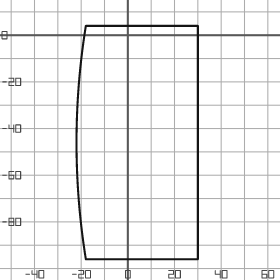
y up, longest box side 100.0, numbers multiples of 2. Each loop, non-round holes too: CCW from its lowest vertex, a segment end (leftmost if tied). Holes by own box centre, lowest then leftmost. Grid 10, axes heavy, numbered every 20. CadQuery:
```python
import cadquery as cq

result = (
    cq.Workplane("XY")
    .moveTo(-18.0, -96.0)
    .lineTo(30.0, -96.0)
    .lineTo(30.0, 4.0)
    .lineTo(-18.0, 4.0)
    .threePointArc((-22.0, -46.0), (-18.0, -96.0))
    .close()
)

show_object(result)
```